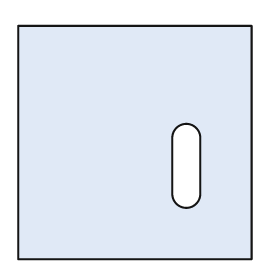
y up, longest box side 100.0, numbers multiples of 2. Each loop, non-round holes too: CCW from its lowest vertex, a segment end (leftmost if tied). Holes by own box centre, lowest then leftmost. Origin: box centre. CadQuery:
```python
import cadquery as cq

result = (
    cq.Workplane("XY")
    .moveTo(-50.0, -50.0)
    .lineTo(50.0, -50.0)
    .lineTo(50.0, 50.0)
    .lineTo(-50.0, 50.0)
    .close()
    .moveTo(16.0, -22.0)
    .threePointArc((22.0, -28.0), (28.0, -22.0))
    .lineTo(28.0, 2.0)
    .threePointArc((22.0, 8.0), (16.0, 2.0))
    .close()
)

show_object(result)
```